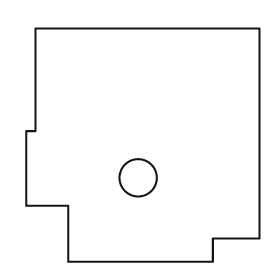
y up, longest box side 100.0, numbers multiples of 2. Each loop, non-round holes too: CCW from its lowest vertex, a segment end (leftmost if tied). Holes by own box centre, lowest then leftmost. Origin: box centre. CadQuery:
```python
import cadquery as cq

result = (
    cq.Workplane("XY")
    .moveTo(-32.0, -50.0)
    .lineTo(30.0, -50.0)
    .lineTo(30.0, -40.0)
    .lineTo(50.0, -40.0)
    .lineTo(50.0, 50.0)
    .lineTo(-46.0, 50.0)
    .lineTo(-46.0, 6.0)
    .lineTo(-50.0, 6.0)
    .lineTo(-50.0, -26.0)
    .lineTo(-32.0, -26.0)
    .close()
    .moveTo(-2.0, -14.0)
    .circle(8.0)
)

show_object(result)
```